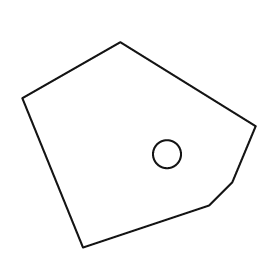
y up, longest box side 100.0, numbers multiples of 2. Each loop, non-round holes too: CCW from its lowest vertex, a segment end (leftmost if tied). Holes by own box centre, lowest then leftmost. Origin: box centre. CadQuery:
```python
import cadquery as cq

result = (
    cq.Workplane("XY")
    .moveTo(-24.0, -44.0)
    .lineTo(30.0, -26.0)
    .lineTo(40.0, -16.0)
    .lineTo(50.0, 8.0)
    .lineTo(-8.0, 44.0)
    .lineTo(-50.0, 20.0)
    .close()
    .moveTo(12.0, -4.0)
    .circle(6.0)
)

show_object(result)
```